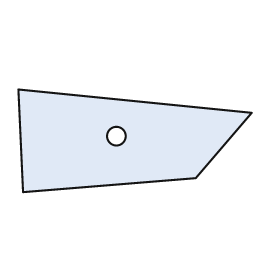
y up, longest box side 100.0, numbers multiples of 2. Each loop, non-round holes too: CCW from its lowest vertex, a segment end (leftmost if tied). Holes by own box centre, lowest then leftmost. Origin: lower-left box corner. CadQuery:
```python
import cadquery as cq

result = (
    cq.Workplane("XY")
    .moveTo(2.0, 0.0)
    .lineTo(76.0, 6.0)
    .lineTo(100.0, 34.0)
    .lineTo(0.0, 44.0)
    .close()
    .moveTo(42.0, 24.0)
    .circle(4.0)
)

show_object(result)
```